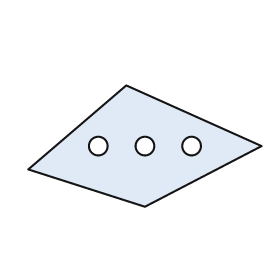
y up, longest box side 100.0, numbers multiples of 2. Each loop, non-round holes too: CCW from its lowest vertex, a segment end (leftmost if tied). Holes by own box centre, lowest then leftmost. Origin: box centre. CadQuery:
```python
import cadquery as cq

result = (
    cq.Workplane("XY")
    .moveTo(0.0, -26.0)
    .lineTo(50.0, 0.0)
    .lineTo(-8.0, 26.0)
    .lineTo(-50.0, -10.0)
    .close()
    .moveTo(-20.0, 0.0)
    .circle(4.0)
    .moveTo(0.0, 0.0)
    .circle(4.0)
    .moveTo(20.0, 0.0)
    .circle(4.0)
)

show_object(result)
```